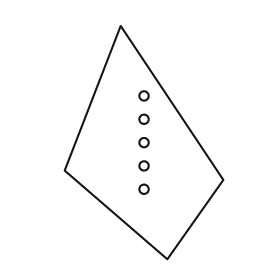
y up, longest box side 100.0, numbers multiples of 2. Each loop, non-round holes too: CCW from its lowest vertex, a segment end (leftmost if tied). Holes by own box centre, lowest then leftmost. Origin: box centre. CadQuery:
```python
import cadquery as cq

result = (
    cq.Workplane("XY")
    .moveTo(10.0, -50.0)
    .lineTo(34.0, -16.0)
    .lineTo(-10.0, 50.0)
    .lineTo(-34.0, -12.0)
    .close()
    .moveTo(0.0, -20.0)
    .circle(2.0)
    .moveTo(0.0, -10.0)
    .circle(2.0)
    .moveTo(0.0, 0.0)
    .circle(2.0)
    .moveTo(0.0, 10.0)
    .circle(2.0)
    .moveTo(0.0, 20.0)
    .circle(2.0)
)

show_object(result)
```